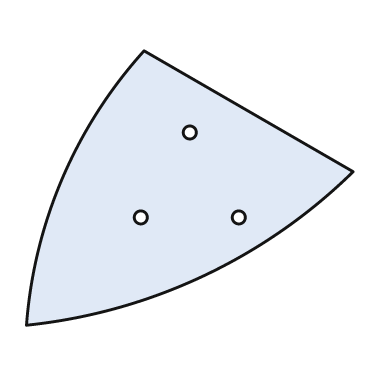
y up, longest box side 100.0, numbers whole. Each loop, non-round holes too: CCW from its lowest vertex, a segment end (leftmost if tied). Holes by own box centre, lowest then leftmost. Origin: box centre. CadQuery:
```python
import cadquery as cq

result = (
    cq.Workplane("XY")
    .moveTo(-50.0, -42.0)
    .threePointArc((4.0, -27.0), (50.0, 5.0))
    .lineTo(-14.0, 42.0)
    .threePointArc((-39.0, 3.0), (-50.0, -42.0))
    .close()
    .moveTo(-15.0, -9.0)
    .circle(2.0)
    .moveTo(15.0, -9.0)
    .circle(2.0)
    .moveTo(0.0, 17.0)
    .circle(2.0)
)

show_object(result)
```